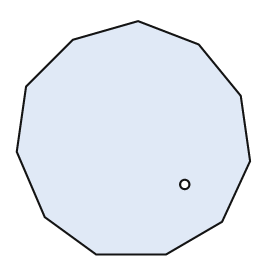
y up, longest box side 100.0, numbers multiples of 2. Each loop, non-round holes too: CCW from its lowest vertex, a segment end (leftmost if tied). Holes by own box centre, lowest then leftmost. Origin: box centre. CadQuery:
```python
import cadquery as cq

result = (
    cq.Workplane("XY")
    .moveTo(-16.0, -50.0)
    .lineTo(14.0, -50.0)
    .lineTo(38.0, -36.0)
    .lineTo(50.0, -10.0)
    .lineTo(46.0, 18.0)
    .lineTo(28.0, 40.0)
    .lineTo(2.0, 50.0)
    .lineTo(-26.0, 42.0)
    .lineTo(-46.0, 22.0)
    .lineTo(-50.0, -6.0)
    .lineTo(-38.0, -34.0)
    .close()
    .moveTo(22.0, -20.0)
    .circle(2.0)
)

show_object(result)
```